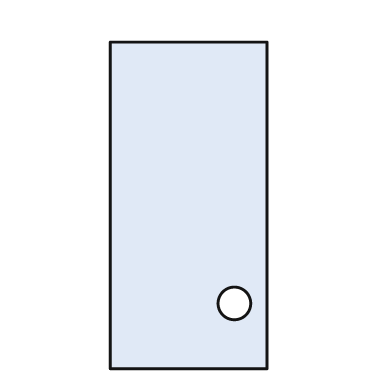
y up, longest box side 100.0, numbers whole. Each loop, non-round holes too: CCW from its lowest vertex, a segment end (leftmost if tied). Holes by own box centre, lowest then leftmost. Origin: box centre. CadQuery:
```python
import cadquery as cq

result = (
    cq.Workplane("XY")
    .moveTo(-24.0, -50.0)
    .lineTo(24.0, -50.0)
    .lineTo(24.0, 50.0)
    .lineTo(-24.0, 50.0)
    .close()
    .moveTo(14.0, -30.0)
    .circle(5.0)
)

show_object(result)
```